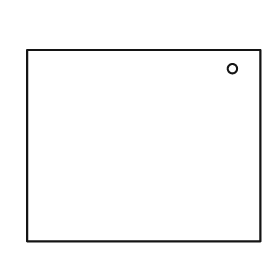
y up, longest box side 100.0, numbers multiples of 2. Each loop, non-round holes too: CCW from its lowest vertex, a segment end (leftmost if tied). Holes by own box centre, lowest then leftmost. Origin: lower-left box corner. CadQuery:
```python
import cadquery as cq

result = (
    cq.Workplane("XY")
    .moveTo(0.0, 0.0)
    .lineTo(100.0, 0.0)
    .lineTo(100.0, 82.0)
    .lineTo(0.0, 82.0)
    .close()
    .moveTo(88.0, 74.0)
    .circle(2.0)
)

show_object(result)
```